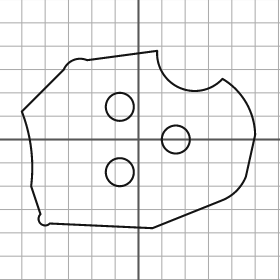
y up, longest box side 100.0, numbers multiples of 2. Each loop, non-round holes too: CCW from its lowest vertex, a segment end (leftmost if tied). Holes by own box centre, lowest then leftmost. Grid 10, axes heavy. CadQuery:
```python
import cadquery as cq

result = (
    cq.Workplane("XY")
    .moveTo(6.0, -38.0)
    .lineTo(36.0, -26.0)
    .threePointArc((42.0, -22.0), (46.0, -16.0))
    .lineTo(50.0, 2.0)
    .threePointArc((46.0, 16.0), (36.0, 26.0))
    .threePointArc((18.0, 22.0), (8.0, 38.0))
    .lineTo(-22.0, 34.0)
    .threePointArc((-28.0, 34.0), (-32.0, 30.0))
    .lineTo(-50.0, 12.0)
    .threePointArc((-46.0, -4.0), (-46.0, -20.0))
    .lineTo(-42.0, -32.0)
    .threePointArc((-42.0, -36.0), (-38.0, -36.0))
    .close()
    .moveTo(-8.0, -14.0)
    .circle(6.0)
    .moveTo(16.0, 0.0)
    .circle(6.0)
    .moveTo(-8.0, 14.0)
    .circle(6.0)
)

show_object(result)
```